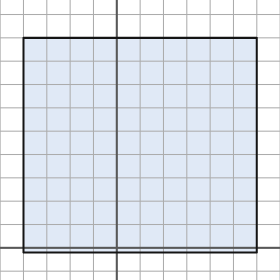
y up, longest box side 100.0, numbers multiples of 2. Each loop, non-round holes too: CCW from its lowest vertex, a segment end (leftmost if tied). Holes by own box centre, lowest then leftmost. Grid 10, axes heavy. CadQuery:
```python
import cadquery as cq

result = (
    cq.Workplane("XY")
    .moveTo(-40.0, -2.0)
    .lineTo(60.0, -2.0)
    .lineTo(60.0, 90.0)
    .lineTo(-40.0, 90.0)
    .close()
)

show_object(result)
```